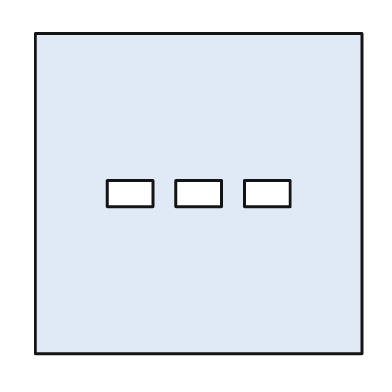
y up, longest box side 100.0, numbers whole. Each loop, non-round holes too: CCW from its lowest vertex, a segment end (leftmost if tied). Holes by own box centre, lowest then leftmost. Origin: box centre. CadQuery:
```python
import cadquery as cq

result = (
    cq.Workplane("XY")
    .moveTo(-50.0, -49.0)
    .lineTo(50.0, -49.0)
    .lineTo(50.0, 49.0)
    .lineTo(-50.0, 49.0)
    .close()
    .moveTo(-28.0, -4.0)
    .lineTo(-14.0, -4.0)
    .lineTo(-14.0, 4.0)
    .lineTo(-28.0, 4.0)
    .close()
    .moveTo(-7.0, -4.0)
    .lineTo(7.0, -4.0)
    .lineTo(7.0, 4.0)
    .lineTo(-7.0, 4.0)
    .close()
    .moveTo(14.0, -4.0)
    .lineTo(28.0, -4.0)
    .lineTo(28.0, 4.0)
    .lineTo(14.0, 4.0)
    .close()
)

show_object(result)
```